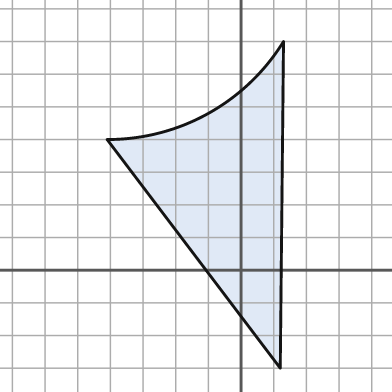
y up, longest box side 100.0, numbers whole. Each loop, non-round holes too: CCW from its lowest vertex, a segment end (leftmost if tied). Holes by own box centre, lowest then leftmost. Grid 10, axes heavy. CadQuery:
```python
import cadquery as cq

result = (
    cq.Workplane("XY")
    .moveTo(12.0, -30.0)
    .lineTo(13.0, 70.0)
    .threePointArc((-10.0, 48.0), (-41.0, 40.0))
    .close()
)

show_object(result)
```